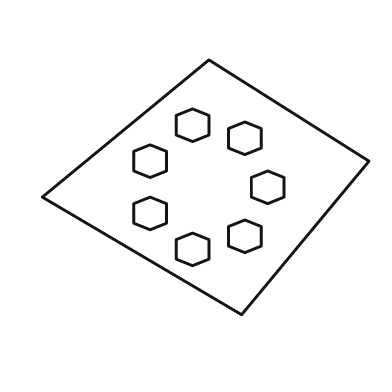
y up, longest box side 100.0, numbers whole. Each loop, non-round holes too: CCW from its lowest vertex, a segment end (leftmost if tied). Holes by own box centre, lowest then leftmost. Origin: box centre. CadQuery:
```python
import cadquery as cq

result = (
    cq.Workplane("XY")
    .moveTo(11.0, -39.0)
    .lineTo(50.0, 8.0)
    .lineTo(1.0, 39.0)
    .lineTo(-50.0, -3.0)
    .close()
    .moveTo(-4.0, -24.0)
    .lineTo(1.0, -22.0)
    .lineTo(1.0, -16.0)
    .lineTo(-4.0, -14.0)
    .lineTo(-9.0, -16.0)
    .lineTo(-9.0, -22.0)
    .close()
    .moveTo(12.0, -20.0)
    .lineTo(17.0, -18.0)
    .lineTo(17.0, -12.0)
    .lineTo(12.0, -10.0)
    .lineTo(7.0, -12.0)
    .lineTo(7.0, -18.0)
    .close()
    .moveTo(-17.0, -13.0)
    .lineTo(-12.0, -11.0)
    .lineTo(-12.0, -5.0)
    .lineTo(-17.0, -3.0)
    .lineTo(-22.0, -5.0)
    .lineTo(-22.0, -11.0)
    .close()
    .moveTo(19.0, -5.0)
    .lineTo(24.0, -3.0)
    .lineTo(24.0, 3.0)
    .lineTo(19.0, 5.0)
    .lineTo(14.0, 3.0)
    .lineTo(14.0, -3.0)
    .close()
    .moveTo(-17.0, 3.0)
    .lineTo(-12.0, 5.0)
    .lineTo(-12.0, 11.0)
    .lineTo(-17.0, 13.0)
    .lineTo(-22.0, 11.0)
    .lineTo(-22.0, 5.0)
    .close()
    .moveTo(12.0, 10.0)
    .lineTo(17.0, 12.0)
    .lineTo(17.0, 18.0)
    .lineTo(12.0, 20.0)
    .lineTo(7.0, 18.0)
    .lineTo(7.0, 12.0)
    .close()
    .moveTo(-4.0, 14.0)
    .lineTo(1.0, 16.0)
    .lineTo(1.0, 22.0)
    .lineTo(-4.0, 24.0)
    .lineTo(-9.0, 22.0)
    .lineTo(-9.0, 16.0)
    .close()
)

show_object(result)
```